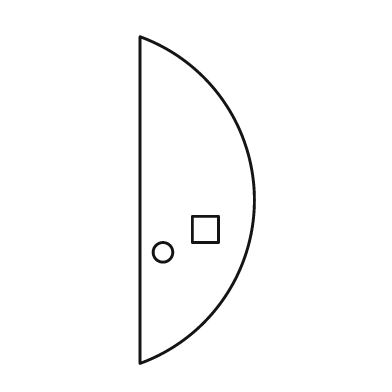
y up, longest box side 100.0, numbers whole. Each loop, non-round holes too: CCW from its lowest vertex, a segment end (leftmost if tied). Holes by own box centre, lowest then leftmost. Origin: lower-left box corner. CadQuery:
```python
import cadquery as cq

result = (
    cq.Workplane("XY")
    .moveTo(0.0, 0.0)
    .threePointArc((35.0, 50.0), (0.0, 100.0))
    .close()
    .moveTo(7.0, 34.0)
    .circle(3.0)
    .moveTo(16.0, 37.0)
    .lineTo(24.0, 37.0)
    .lineTo(24.0, 45.0)
    .lineTo(16.0, 45.0)
    .close()
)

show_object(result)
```